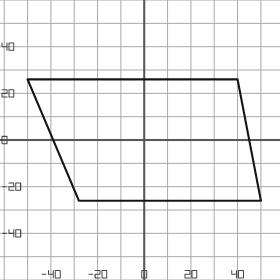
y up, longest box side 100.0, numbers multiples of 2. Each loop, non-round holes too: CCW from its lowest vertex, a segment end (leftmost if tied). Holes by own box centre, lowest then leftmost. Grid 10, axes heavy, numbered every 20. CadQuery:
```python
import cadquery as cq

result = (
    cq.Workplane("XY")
    .moveTo(-28.0, -26.0)
    .lineTo(50.0, -26.0)
    .lineTo(40.0, 26.0)
    .lineTo(-50.0, 26.0)
    .close()
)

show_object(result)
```